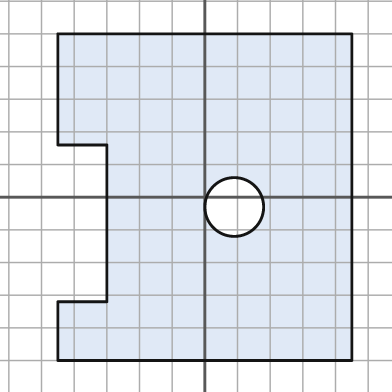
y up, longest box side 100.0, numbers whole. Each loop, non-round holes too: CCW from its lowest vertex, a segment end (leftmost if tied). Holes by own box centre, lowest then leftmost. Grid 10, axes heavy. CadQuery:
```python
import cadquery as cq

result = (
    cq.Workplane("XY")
    .moveTo(-45.0, -50.0)
    .lineTo(45.0, -50.0)
    .lineTo(45.0, 50.0)
    .lineTo(-45.0, 50.0)
    .lineTo(-45.0, 16.0)
    .lineTo(-30.0, 16.0)
    .lineTo(-30.0, -32.0)
    .lineTo(-45.0, -32.0)
    .close()
    .moveTo(9.0, -3.0)
    .circle(9.0)
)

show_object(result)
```